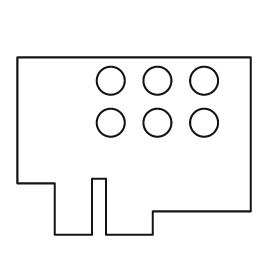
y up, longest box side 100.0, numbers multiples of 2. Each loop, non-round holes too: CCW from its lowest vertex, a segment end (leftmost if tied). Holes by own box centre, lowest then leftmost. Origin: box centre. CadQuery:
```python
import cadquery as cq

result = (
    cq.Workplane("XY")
    .moveTo(-34.0, -38.0)
    .lineTo(-18.0, -38.0)
    .lineTo(-18.0, -14.0)
    .lineTo(-12.0, -14.0)
    .lineTo(-12.0, -38.0)
    .lineTo(8.0, -38.0)
    .lineTo(8.0, -28.0)
    .lineTo(50.0, -28.0)
    .lineTo(50.0, 38.0)
    .lineTo(-50.0, 38.0)
    .lineTo(-50.0, -16.0)
    .lineTo(-34.0, -16.0)
    .close()
    .moveTo(-10.0, 10.0)
    .circle(6.0)
    .moveTo(10.0, 10.0)
    .circle(6.0)
    .moveTo(30.0, 10.0)
    .circle(6.0)
    .moveTo(-10.0, 28.0)
    .circle(6.0)
    .moveTo(10.0, 28.0)
    .circle(6.0)
    .moveTo(30.0, 28.0)
    .circle(6.0)
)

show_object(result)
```